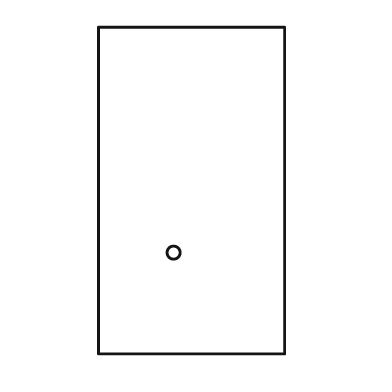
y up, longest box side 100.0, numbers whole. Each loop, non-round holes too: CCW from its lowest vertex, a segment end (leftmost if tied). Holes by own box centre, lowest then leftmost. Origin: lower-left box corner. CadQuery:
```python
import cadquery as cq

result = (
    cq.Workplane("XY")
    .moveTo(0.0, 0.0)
    .lineTo(57.0, 0.0)
    .lineTo(57.0, 100.0)
    .lineTo(0.0, 100.0)
    .close()
    .moveTo(23.0, 31.0)
    .circle(2.0)
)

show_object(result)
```